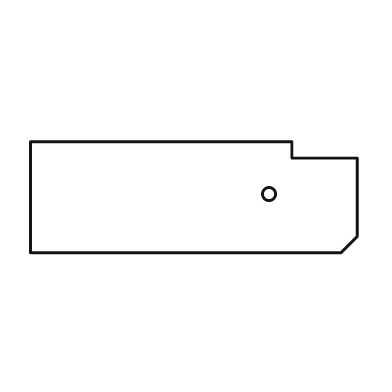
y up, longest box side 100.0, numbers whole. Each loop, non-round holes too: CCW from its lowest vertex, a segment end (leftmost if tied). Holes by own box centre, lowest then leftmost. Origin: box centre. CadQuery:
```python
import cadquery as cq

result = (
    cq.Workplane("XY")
    .moveTo(-50.0, -17.0)
    .lineTo(45.0, -17.0)
    .lineTo(50.0, -12.0)
    .lineTo(50.0, 12.0)
    .lineTo(30.0, 12.0)
    .lineTo(30.0, 17.0)
    .lineTo(-50.0, 17.0)
    .close()
    .moveTo(23.0, 1.0)
    .circle(2.0)
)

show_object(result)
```